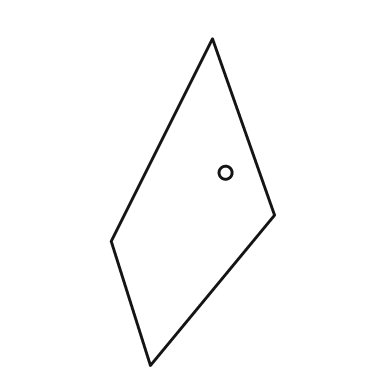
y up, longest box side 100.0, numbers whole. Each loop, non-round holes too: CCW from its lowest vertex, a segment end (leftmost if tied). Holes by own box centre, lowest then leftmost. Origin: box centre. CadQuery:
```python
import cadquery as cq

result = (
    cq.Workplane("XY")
    .moveTo(-13.0, -50.0)
    .lineTo(25.0, -4.0)
    .lineTo(6.0, 50.0)
    .lineTo(-25.0, -12.0)
    .close()
    .moveTo(10.0, 9.0)
    .circle(2.0)
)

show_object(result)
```